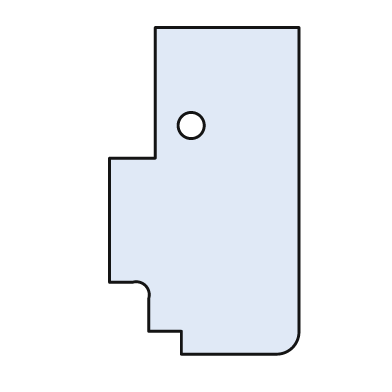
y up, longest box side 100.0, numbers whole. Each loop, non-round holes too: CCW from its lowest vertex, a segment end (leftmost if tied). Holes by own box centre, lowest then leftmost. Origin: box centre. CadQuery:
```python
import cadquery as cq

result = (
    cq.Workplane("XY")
    .moveTo(-7.0, -50.0)
    .lineTo(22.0, -50.0)
    .threePointArc((27.0, -48.0), (29.0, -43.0))
    .lineTo(29.0, 50.0)
    .lineTo(-15.0, 50.0)
    .lineTo(-15.0, 10.0)
    .lineTo(-29.0, 10.0)
    .lineTo(-29.0, -28.0)
    .lineTo(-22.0, -28.0)
    .threePointArc((-18.0, -29.0), (-17.0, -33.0))
    .lineTo(-17.0, -43.0)
    .lineTo(-7.0, -43.0)
    .close()
    .moveTo(-4.0, 20.0)
    .circle(4.0)
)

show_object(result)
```